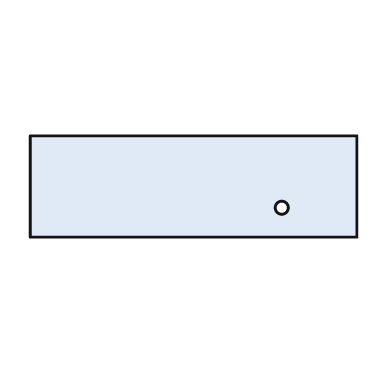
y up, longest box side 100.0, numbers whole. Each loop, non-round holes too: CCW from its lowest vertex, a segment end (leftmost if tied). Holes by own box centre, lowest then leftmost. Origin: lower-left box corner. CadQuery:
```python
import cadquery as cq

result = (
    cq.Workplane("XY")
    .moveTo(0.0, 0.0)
    .lineTo(100.0, 0.0)
    .lineTo(100.0, 31.0)
    .lineTo(0.0, 31.0)
    .close()
    .moveTo(77.0, 9.0)
    .circle(2.0)
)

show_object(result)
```